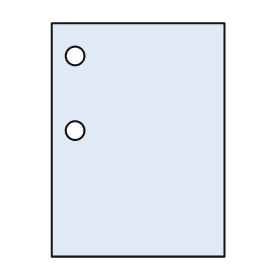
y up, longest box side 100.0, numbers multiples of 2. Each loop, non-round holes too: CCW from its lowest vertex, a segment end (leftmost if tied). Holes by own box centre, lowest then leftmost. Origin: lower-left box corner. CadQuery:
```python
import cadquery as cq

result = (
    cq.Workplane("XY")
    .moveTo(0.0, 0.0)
    .lineTo(74.0, 0.0)
    .lineTo(74.0, 100.0)
    .lineTo(0.0, 100.0)
    .close()
    .moveTo(10.0, 54.0)
    .circle(4.0)
    .moveTo(10.0, 86.0)
    .circle(4.0)
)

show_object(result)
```